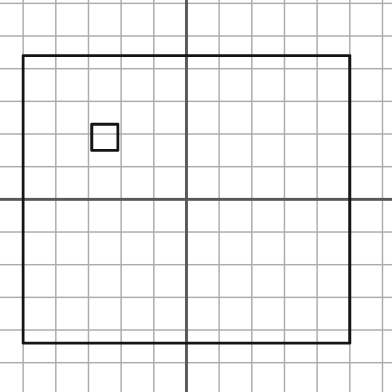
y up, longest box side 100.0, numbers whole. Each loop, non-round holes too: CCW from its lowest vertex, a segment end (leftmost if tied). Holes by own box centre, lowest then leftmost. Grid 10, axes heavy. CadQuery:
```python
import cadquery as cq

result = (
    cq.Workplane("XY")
    .moveTo(-50.0, -44.0)
    .lineTo(50.0, -44.0)
    .lineTo(50.0, 44.0)
    .lineTo(-50.0, 44.0)
    .close()
    .moveTo(-29.0, 15.0)
    .lineTo(-21.0, 15.0)
    .lineTo(-21.0, 23.0)
    .lineTo(-29.0, 23.0)
    .close()
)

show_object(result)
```